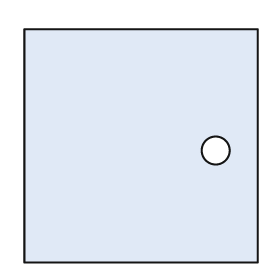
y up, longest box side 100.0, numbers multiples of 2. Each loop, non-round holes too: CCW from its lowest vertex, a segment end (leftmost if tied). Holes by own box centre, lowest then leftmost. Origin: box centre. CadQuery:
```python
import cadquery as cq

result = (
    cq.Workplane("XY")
    .moveTo(-50.0, -50.0)
    .lineTo(50.0, -50.0)
    .lineTo(50.0, 50.0)
    .lineTo(-50.0, 50.0)
    .close()
    .moveTo(32.0, -2.0)
    .circle(6.0)
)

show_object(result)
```